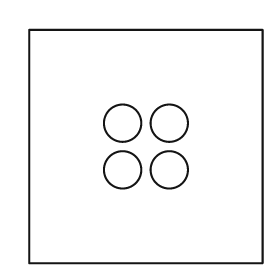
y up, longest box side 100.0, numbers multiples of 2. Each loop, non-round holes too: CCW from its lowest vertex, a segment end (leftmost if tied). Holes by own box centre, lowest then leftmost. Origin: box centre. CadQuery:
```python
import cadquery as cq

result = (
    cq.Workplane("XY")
    .moveTo(-50.0, -50.0)
    .lineTo(50.0, -50.0)
    .lineTo(50.0, 50.0)
    .lineTo(-50.0, 50.0)
    .close()
    .moveTo(-10.0, -10.0)
    .circle(8.0)
    .moveTo(10.0, -10.0)
    .circle(8.0)
    .moveTo(-10.0, 10.0)
    .circle(8.0)
    .moveTo(10.0, 10.0)
    .circle(8.0)
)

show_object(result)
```